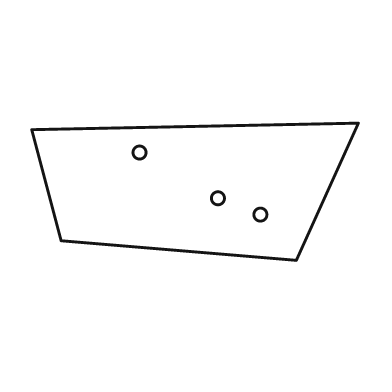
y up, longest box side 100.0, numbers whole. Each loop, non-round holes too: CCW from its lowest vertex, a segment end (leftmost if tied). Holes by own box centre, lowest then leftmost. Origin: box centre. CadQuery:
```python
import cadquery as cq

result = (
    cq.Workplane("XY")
    .moveTo(31.0, -21.0)
    .lineTo(50.0, 21.0)
    .lineTo(-50.0, 19.0)
    .lineTo(-41.0, -15.0)
    .close()
    .moveTo(20.0, -7.0)
    .circle(2.0)
    .moveTo(7.0, -2.0)
    .circle(2.0)
    .moveTo(-17.0, 12.0)
    .circle(2.0)
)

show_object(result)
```